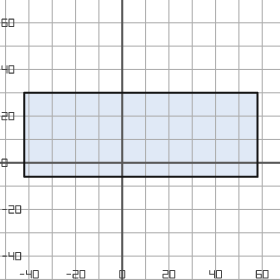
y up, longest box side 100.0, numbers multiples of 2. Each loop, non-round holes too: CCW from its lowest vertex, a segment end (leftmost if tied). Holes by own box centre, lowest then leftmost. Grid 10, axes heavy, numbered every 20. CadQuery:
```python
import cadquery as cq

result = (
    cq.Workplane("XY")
    .moveTo(-42.0, -6.0)
    .lineTo(58.0, -6.0)
    .lineTo(58.0, 30.0)
    .lineTo(-42.0, 30.0)
    .close()
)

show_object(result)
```